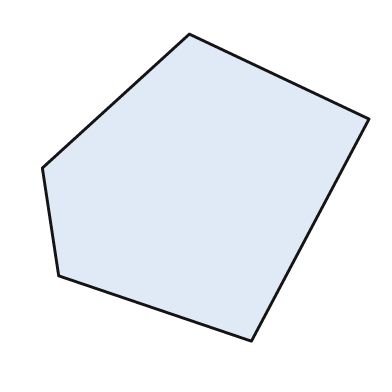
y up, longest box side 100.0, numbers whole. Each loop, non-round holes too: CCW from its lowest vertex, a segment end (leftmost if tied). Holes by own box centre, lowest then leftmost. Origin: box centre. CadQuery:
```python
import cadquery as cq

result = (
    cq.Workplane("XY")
    .moveTo(14.0, -47.0)
    .lineTo(50.0, 21.0)
    .lineTo(-5.0, 47.0)
    .lineTo(-50.0, 6.0)
    .lineTo(-45.0, -27.0)
    .close()
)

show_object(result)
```